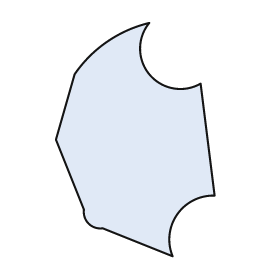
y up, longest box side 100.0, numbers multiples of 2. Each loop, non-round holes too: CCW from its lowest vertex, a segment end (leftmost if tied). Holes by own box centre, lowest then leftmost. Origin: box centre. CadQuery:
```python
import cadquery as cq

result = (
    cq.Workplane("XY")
    .moveTo(16.0, -50.0)
    .threePointArc((18.0, -32.0), (34.0, -24.0))
    .lineTo(28.0, 24.0)
    .threePointArc((6.0, 28.0), (6.0, 50.0))
    .threePointArc((-12.0, 42.0), (-26.0, 28.0))
    .lineTo(-34.0, 0.0)
    .lineTo(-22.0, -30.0)
    .threePointArc((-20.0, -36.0), (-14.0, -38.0))
    .close()
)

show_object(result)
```